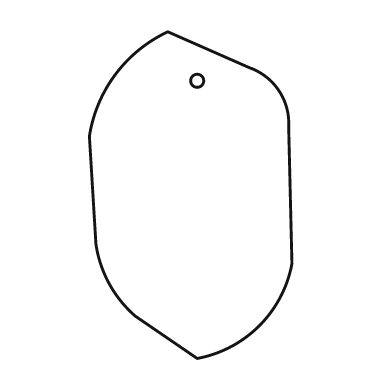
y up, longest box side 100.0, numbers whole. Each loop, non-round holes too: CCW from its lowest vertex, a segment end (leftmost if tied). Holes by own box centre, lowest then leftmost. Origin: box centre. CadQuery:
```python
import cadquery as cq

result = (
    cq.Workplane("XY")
    .moveTo(2.0, -50.0)
    .threePointArc((21.0, -40.0), (31.0, -21.0))
    .lineTo(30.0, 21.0)
    .threePointArc((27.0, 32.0), (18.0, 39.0))
    .lineTo(-7.0, 50.0)
    .threePointArc((-23.0, 37.0), (-31.0, 18.0))
    .lineTo(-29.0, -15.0)
    .threePointArc((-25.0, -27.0), (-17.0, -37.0))
    .close()
    .moveTo(2.0, 35.0)
    .circle(2.0)
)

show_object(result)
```